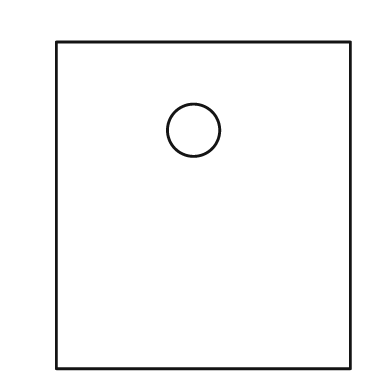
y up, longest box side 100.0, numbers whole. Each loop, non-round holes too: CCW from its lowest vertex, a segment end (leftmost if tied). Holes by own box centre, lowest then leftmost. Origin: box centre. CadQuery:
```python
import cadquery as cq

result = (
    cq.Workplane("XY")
    .moveTo(-45.0, -50.0)
    .lineTo(45.0, -50.0)
    .lineTo(45.0, 50.0)
    .lineTo(-45.0, 50.0)
    .close()
    .moveTo(-3.0, 23.0)
    .circle(8.0)
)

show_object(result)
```